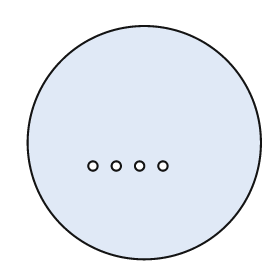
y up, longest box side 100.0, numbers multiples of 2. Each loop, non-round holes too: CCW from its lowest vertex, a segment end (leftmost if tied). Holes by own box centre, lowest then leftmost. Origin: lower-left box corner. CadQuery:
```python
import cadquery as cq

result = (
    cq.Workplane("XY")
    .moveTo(50.0, 50.0)
    .circle(50.0)
    .moveTo(28.0, 40.0)
    .circle(2.0)
    .moveTo(38.0, 40.0)
    .circle(2.0)
    .moveTo(48.0, 40.0)
    .circle(2.0)
    .moveTo(58.0, 40.0)
    .circle(2.0)
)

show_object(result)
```